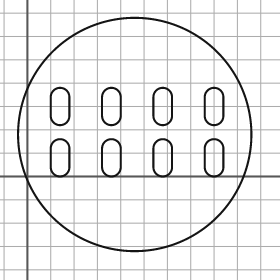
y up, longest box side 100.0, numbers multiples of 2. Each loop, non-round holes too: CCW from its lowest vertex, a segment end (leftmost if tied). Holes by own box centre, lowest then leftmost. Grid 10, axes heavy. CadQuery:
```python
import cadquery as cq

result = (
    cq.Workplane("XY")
    .moveTo(46.0, 18.0)
    .circle(50.0)
    .moveTo(10.0, 4.0)
    .threePointArc((14.0, 0.0), (18.0, 4.0))
    .lineTo(18.0, 12.0)
    .threePointArc((14.0, 16.0), (10.0, 12.0))
    .close()
    .moveTo(32.0, 4.0)
    .threePointArc((36.0, 0.0), (40.0, 4.0))
    .lineTo(40.0, 12.0)
    .threePointArc((36.0, 16.0), (32.0, 12.0))
    .close()
    .moveTo(54.0, 4.0)
    .threePointArc((58.0, 0.0), (62.0, 4.0))
    .lineTo(62.0, 12.0)
    .threePointArc((58.0, 16.0), (54.0, 12.0))
    .close()
    .moveTo(76.0, 4.0)
    .threePointArc((80.0, 0.0), (84.0, 4.0))
    .lineTo(84.0, 12.0)
    .threePointArc((80.0, 16.0), (76.0, 12.0))
    .close()
    .moveTo(10.0, 26.0)
    .threePointArc((14.0, 22.0), (18.0, 26.0))
    .lineTo(18.0, 34.0)
    .threePointArc((14.0, 38.0), (10.0, 34.0))
    .close()
    .moveTo(32.0, 26.0)
    .threePointArc((36.0, 22.0), (40.0, 26.0))
    .lineTo(40.0, 34.0)
    .threePointArc((36.0, 38.0), (32.0, 34.0))
    .close()
    .moveTo(54.0, 26.0)
    .threePointArc((58.0, 22.0), (62.0, 26.0))
    .lineTo(62.0, 34.0)
    .threePointArc((58.0, 38.0), (54.0, 34.0))
    .close()
    .moveTo(76.0, 26.0)
    .threePointArc((80.0, 22.0), (84.0, 26.0))
    .lineTo(84.0, 34.0)
    .threePointArc((80.0, 38.0), (76.0, 34.0))
    .close()
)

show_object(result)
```